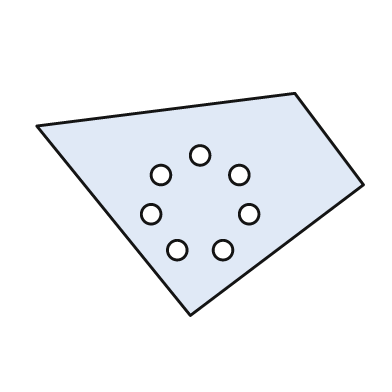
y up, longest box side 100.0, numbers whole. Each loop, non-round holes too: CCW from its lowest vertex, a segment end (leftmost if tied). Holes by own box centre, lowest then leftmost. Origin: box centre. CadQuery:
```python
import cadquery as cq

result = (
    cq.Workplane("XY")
    .moveTo(-3.0, -34.0)
    .lineTo(50.0, 6.0)
    .lineTo(29.0, 34.0)
    .lineTo(-50.0, 24.0)
    .close()
    .moveTo(-7.0, -14.0)
    .circle(3.0)
    .moveTo(7.0, -14.0)
    .circle(3.0)
    .moveTo(-15.0, -3.0)
    .circle(3.0)
    .moveTo(15.0, -3.0)
    .circle(3.0)
    .moveTo(-12.0, 9.0)
    .circle(3.0)
    .moveTo(12.0, 9.0)
    .circle(3.0)
    .moveTo(0.0, 15.0)
    .circle(3.0)
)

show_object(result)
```